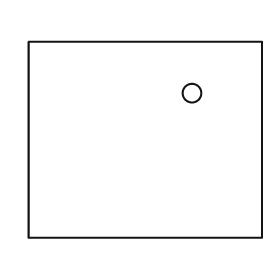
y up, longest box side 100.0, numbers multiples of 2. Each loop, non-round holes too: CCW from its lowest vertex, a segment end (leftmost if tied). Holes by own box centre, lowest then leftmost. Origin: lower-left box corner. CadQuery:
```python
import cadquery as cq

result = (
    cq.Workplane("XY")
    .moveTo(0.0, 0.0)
    .lineTo(100.0, 0.0)
    .lineTo(100.0, 84.0)
    .lineTo(0.0, 84.0)
    .close()
    .moveTo(70.0, 62.0)
    .circle(4.0)
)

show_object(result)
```